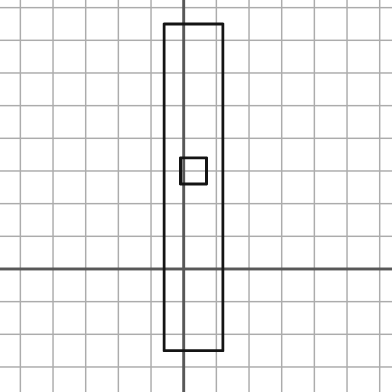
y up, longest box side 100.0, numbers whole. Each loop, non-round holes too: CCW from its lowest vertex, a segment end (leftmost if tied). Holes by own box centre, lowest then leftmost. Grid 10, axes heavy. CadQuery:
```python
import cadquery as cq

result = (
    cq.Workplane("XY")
    .moveTo(-6.0, -25.0)
    .lineTo(12.0, -25.0)
    .lineTo(12.0, 75.0)
    .lineTo(-6.0, 75.0)
    .close()
    .moveTo(-1.0, 26.0)
    .lineTo(7.0, 26.0)
    .lineTo(7.0, 34.0)
    .lineTo(-1.0, 34.0)
    .close()
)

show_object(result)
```